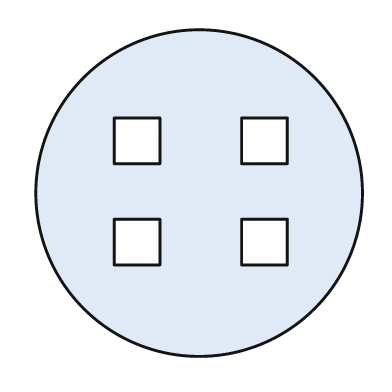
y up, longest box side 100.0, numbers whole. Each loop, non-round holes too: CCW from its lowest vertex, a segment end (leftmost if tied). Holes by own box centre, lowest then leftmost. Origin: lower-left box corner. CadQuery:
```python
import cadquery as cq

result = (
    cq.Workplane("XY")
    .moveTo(50.0, 50.0)
    .circle(50.0)
    .moveTo(24.0, 28.0)
    .lineTo(38.0, 28.0)
    .lineTo(38.0, 42.0)
    .lineTo(24.0, 42.0)
    .close()
    .moveTo(63.0, 28.0)
    .lineTo(77.0, 28.0)
    .lineTo(77.0, 42.0)
    .lineTo(63.0, 42.0)
    .close()
    .moveTo(24.0, 59.0)
    .lineTo(38.0, 59.0)
    .lineTo(38.0, 73.0)
    .lineTo(24.0, 73.0)
    .close()
    .moveTo(63.0, 59.0)
    .lineTo(77.0, 59.0)
    .lineTo(77.0, 73.0)
    .lineTo(63.0, 73.0)
    .close()
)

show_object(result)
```